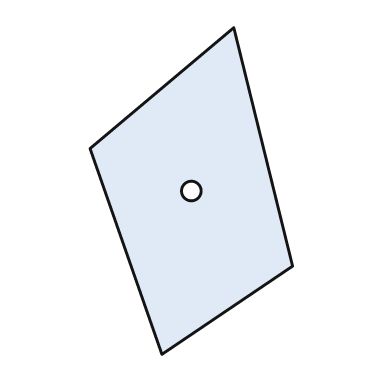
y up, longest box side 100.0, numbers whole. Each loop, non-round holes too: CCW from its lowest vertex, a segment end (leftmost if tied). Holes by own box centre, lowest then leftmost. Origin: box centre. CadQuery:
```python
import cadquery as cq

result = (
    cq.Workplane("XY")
    .moveTo(-9.0, -50.0)
    .lineTo(31.0, -23.0)
    .lineTo(13.0, 50.0)
    .lineTo(-31.0, 13.0)
    .close()
    .moveTo(0.0, 0.0)
    .circle(3.0)
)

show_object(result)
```